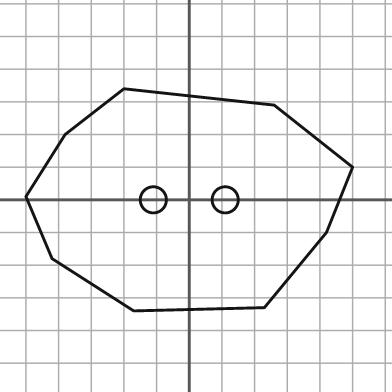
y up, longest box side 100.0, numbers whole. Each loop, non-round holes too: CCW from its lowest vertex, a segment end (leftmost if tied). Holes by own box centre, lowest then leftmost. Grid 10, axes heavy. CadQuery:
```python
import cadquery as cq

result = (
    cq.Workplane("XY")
    .moveTo(-17.0, -34.0)
    .lineTo(23.0, -33.0)
    .lineTo(42.0, -10.0)
    .lineTo(50.0, 10.0)
    .lineTo(26.0, 29.0)
    .lineTo(-20.0, 34.0)
    .lineTo(-38.0, 20.0)
    .lineTo(-50.0, 1.0)
    .lineTo(-42.0, -18.0)
    .close()
    .moveTo(-11.0, 0.0)
    .circle(4.0)
    .moveTo(11.0, 0.0)
    .circle(4.0)
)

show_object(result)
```